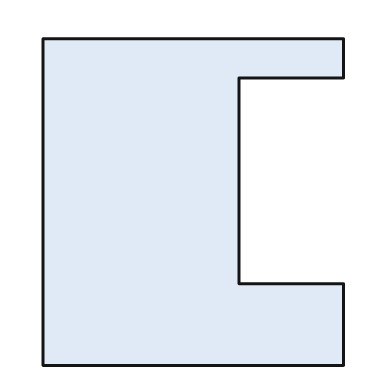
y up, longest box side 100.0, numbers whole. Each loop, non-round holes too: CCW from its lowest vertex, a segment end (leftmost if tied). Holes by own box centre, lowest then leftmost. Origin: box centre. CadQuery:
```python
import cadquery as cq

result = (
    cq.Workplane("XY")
    .moveTo(-46.0, -50.0)
    .lineTo(46.0, -50.0)
    .lineTo(46.0, -25.0)
    .lineTo(14.0, -25.0)
    .lineTo(14.0, 38.0)
    .lineTo(46.0, 38.0)
    .lineTo(46.0, 50.0)
    .lineTo(-46.0, 50.0)
    .close()
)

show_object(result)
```